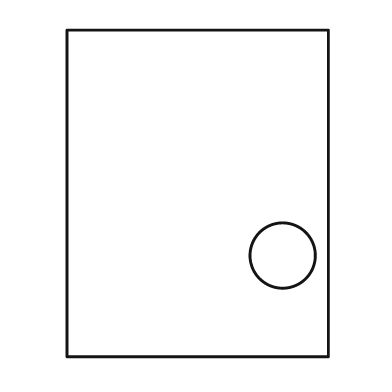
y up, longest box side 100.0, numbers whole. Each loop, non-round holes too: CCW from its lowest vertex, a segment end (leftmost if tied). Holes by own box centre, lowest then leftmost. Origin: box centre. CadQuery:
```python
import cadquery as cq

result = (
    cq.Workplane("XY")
    .moveTo(-40.0, -50.0)
    .lineTo(40.0, -50.0)
    .lineTo(40.0, 50.0)
    .lineTo(-40.0, 50.0)
    .close()
    .moveTo(26.0, -19.0)
    .circle(10.0)
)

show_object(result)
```